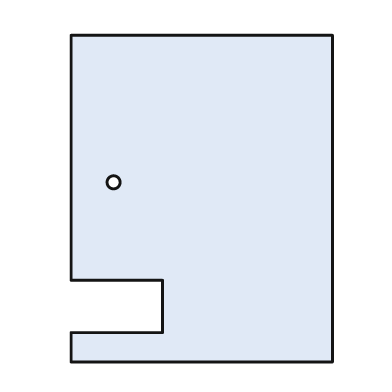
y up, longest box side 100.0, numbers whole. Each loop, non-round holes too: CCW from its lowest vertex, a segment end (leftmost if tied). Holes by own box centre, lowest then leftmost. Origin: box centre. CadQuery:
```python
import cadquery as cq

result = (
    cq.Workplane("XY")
    .moveTo(-40.0, -50.0)
    .lineTo(40.0, -50.0)
    .lineTo(40.0, 50.0)
    .lineTo(-40.0, 50.0)
    .lineTo(-40.0, -25.0)
    .lineTo(-12.0, -25.0)
    .lineTo(-12.0, -41.0)
    .lineTo(-40.0, -41.0)
    .close()
    .moveTo(-27.0, 5.0)
    .circle(2.0)
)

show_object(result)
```